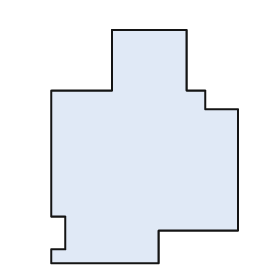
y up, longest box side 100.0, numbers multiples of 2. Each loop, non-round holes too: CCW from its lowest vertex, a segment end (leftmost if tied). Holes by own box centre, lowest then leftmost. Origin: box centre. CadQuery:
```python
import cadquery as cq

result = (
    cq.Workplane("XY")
    .moveTo(-40.0, -50.0)
    .lineTo(6.0, -50.0)
    .lineTo(6.0, -36.0)
    .lineTo(40.0, -36.0)
    .lineTo(40.0, 16.0)
    .lineTo(26.0, 16.0)
    .lineTo(26.0, 24.0)
    .lineTo(18.0, 24.0)
    .lineTo(18.0, 50.0)
    .lineTo(-14.0, 50.0)
    .lineTo(-14.0, 24.0)
    .lineTo(-40.0, 24.0)
    .lineTo(-40.0, -30.0)
    .lineTo(-34.0, -30.0)
    .lineTo(-34.0, -44.0)
    .lineTo(-40.0, -44.0)
    .close()
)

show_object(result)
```